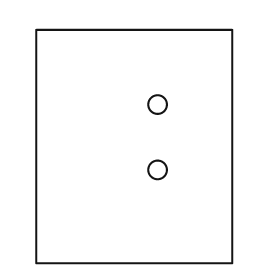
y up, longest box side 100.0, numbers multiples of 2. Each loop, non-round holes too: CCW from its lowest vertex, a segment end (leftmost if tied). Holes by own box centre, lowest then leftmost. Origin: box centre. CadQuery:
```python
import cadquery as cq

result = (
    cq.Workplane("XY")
    .moveTo(-42.0, -50.0)
    .lineTo(42.0, -50.0)
    .lineTo(42.0, 50.0)
    .lineTo(-42.0, 50.0)
    .close()
    .moveTo(10.0, -10.0)
    .circle(4.0)
    .moveTo(10.0, 18.0)
    .circle(4.0)
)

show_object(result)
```